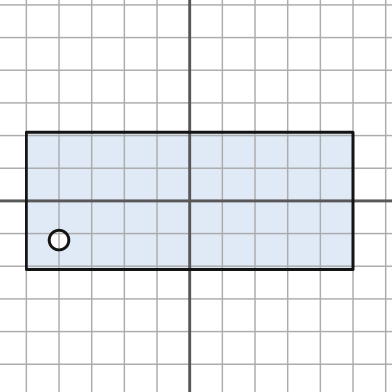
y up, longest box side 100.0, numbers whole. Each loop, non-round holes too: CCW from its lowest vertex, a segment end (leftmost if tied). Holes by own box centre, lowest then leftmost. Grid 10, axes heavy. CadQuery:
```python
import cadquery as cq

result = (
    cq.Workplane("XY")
    .moveTo(-50.0, -21.0)
    .lineTo(50.0, -21.0)
    .lineTo(50.0, 21.0)
    .lineTo(-50.0, 21.0)
    .close()
    .moveTo(-40.0, -12.0)
    .circle(3.0)
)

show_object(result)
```